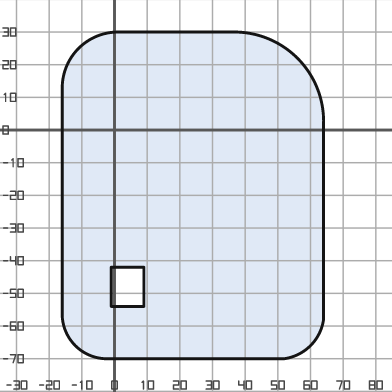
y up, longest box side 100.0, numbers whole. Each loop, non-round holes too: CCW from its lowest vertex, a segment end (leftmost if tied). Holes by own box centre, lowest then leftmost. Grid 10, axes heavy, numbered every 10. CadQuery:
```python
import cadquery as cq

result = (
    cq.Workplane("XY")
    .moveTo(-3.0, -70.0)
    .lineTo(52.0, -70.0)
    .threePointArc((60.0, -66.0), (64.0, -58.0))
    .lineTo(64.0, 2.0)
    .threePointArc((56.0, 22.0), (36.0, 30.0))
    .lineTo(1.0, 30.0)
    .threePointArc((-11.0, 25.0), (-16.0, 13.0))
    .lineTo(-16.0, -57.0)
    .threePointArc((-12.0, -66.0), (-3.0, -70.0))
    .close()
    .moveTo(-1.0, -54.0)
    .lineTo(9.0, -54.0)
    .lineTo(9.0, -42.0)
    .lineTo(-1.0, -42.0)
    .close()
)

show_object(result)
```